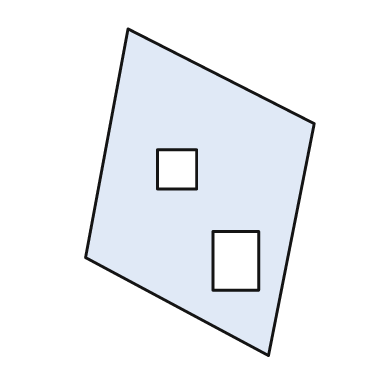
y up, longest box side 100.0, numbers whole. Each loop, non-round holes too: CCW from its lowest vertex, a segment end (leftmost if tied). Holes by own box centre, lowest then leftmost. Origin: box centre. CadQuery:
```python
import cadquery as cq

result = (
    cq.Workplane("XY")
    .moveTo(21.0, -50.0)
    .lineTo(35.0, 21.0)
    .lineTo(-22.0, 50.0)
    .lineTo(-35.0, -20.0)
    .close()
    .moveTo(4.0, -30.0)
    .lineTo(18.0, -30.0)
    .lineTo(18.0, -12.0)
    .lineTo(4.0, -12.0)
    .close()
    .moveTo(-13.0, 1.0)
    .lineTo(-1.0, 1.0)
    .lineTo(-1.0, 13.0)
    .lineTo(-13.0, 13.0)
    .close()
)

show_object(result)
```